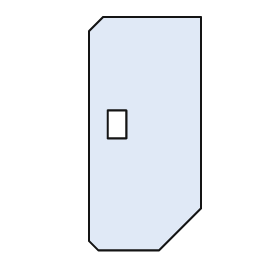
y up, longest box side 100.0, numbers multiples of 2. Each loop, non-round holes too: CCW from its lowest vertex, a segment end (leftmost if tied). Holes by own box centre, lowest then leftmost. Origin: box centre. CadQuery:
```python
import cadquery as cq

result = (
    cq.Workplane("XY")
    .moveTo(-20.0, -50.0)
    .lineTo(6.0, -50.0)
    .lineTo(24.0, -32.0)
    .lineTo(24.0, 50.0)
    .lineTo(-18.0, 50.0)
    .lineTo(-24.0, 44.0)
    .lineTo(-24.0, -46.0)
    .close()
    .moveTo(-16.0, -2.0)
    .lineTo(-8.0, -2.0)
    .lineTo(-8.0, 10.0)
    .lineTo(-16.0, 10.0)
    .close()
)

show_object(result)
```